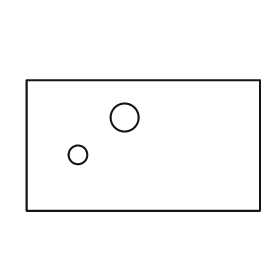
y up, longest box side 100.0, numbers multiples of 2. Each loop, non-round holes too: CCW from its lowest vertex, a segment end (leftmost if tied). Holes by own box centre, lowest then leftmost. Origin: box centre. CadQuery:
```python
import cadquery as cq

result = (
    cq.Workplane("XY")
    .moveTo(-50.0, -28.0)
    .lineTo(50.0, -28.0)
    .lineTo(50.0, 28.0)
    .lineTo(-50.0, 28.0)
    .close()
    .moveTo(-28.0, -4.0)
    .circle(4.0)
    .moveTo(-8.0, 12.0)
    .circle(6.0)
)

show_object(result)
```